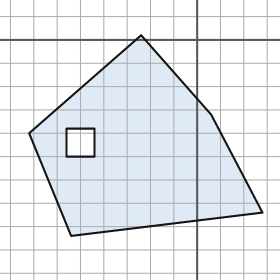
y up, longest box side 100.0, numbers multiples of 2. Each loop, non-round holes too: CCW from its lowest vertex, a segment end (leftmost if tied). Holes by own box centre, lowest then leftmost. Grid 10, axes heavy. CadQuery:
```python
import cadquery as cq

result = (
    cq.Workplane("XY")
    .moveTo(-54.0, -84.0)
    .lineTo(28.0, -74.0)
    .lineTo(6.0, -32.0)
    .lineTo(-24.0, 2.0)
    .lineTo(-72.0, -40.0)
    .close()
    .moveTo(-56.0, -50.0)
    .lineTo(-44.0, -50.0)
    .lineTo(-44.0, -38.0)
    .lineTo(-56.0, -38.0)
    .close()
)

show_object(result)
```